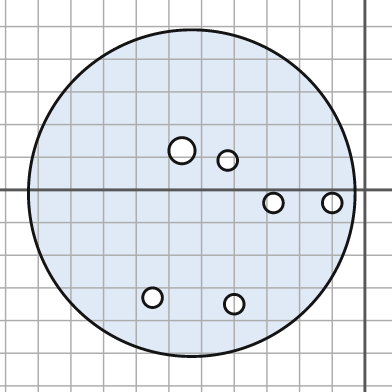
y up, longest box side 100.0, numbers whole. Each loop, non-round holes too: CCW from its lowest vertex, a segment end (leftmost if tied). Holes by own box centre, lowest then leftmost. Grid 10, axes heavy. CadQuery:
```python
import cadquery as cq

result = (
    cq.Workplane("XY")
    .moveTo(-53.0, -1.0)
    .circle(50.0)
    .moveTo(-40.0, -35.0)
    .circle(3.0)
    .moveTo(-65.0, -33.0)
    .circle(3.0)
    .moveTo(-28.0, -4.0)
    .circle(3.0)
    .moveTo(-10.0, -4.0)
    .circle(3.0)
    .moveTo(-42.0, 9.0)
    .circle(3.0)
    .moveTo(-56.0, 12.0)
    .circle(4.0)
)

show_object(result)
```